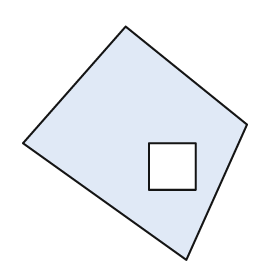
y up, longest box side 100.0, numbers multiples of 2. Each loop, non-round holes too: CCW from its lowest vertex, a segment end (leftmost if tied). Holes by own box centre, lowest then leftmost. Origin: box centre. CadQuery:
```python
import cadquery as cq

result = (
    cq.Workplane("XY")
    .moveTo(22.0, -50.0)
    .lineTo(48.0, 8.0)
    .lineTo(-4.0, 50.0)
    .lineTo(-48.0, 0.0)
    .close()
    .moveTo(6.0, -20.0)
    .lineTo(26.0, -20.0)
    .lineTo(26.0, 0.0)
    .lineTo(6.0, 0.0)
    .close()
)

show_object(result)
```